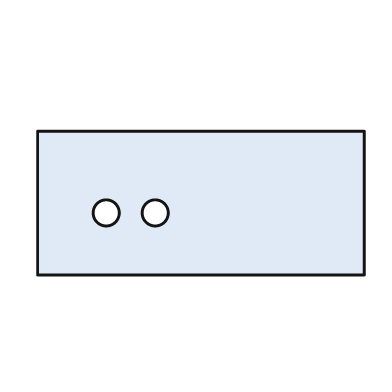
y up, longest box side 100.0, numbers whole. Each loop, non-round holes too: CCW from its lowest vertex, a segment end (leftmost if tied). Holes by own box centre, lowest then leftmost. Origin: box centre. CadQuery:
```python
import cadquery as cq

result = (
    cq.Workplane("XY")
    .moveTo(-50.0, -22.0)
    .lineTo(50.0, -22.0)
    .lineTo(50.0, 22.0)
    .lineTo(-50.0, 22.0)
    .close()
    .moveTo(-29.0, -3.0)
    .circle(4.0)
    .moveTo(-14.0, -3.0)
    .circle(4.0)
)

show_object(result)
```